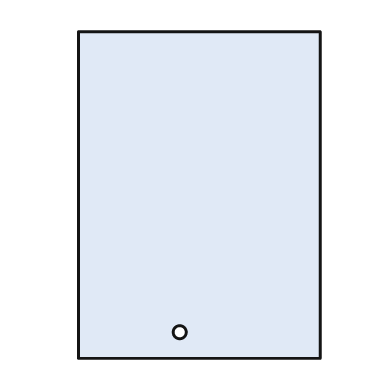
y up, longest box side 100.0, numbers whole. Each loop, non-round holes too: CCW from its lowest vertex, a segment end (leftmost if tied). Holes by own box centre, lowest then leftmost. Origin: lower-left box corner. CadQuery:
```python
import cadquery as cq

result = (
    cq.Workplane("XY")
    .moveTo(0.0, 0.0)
    .lineTo(74.0, 0.0)
    .lineTo(74.0, 100.0)
    .lineTo(0.0, 100.0)
    .close()
    .moveTo(31.0, 8.0)
    .circle(2.0)
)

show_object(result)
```